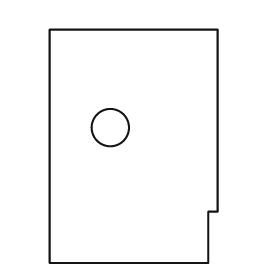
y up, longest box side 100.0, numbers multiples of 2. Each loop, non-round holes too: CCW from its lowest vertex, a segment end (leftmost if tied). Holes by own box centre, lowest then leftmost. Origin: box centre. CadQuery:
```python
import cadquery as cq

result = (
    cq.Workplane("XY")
    .moveTo(-36.0, -50.0)
    .lineTo(32.0, -50.0)
    .lineTo(32.0, -28.0)
    .lineTo(36.0, -28.0)
    .lineTo(36.0, 50.0)
    .lineTo(-36.0, 50.0)
    .close()
    .moveTo(-10.0, 8.0)
    .circle(8.0)
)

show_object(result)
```